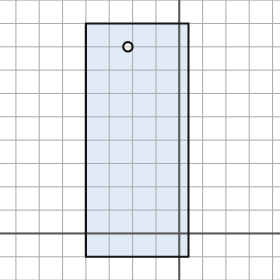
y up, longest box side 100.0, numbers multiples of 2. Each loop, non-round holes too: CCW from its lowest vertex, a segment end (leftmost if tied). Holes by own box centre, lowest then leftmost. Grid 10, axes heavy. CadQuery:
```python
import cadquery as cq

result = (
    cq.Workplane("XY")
    .moveTo(-40.0, -10.0)
    .lineTo(4.0, -10.0)
    .lineTo(4.0, 90.0)
    .lineTo(-40.0, 90.0)
    .close()
    .moveTo(-22.0, 80.0)
    .circle(2.0)
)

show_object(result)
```